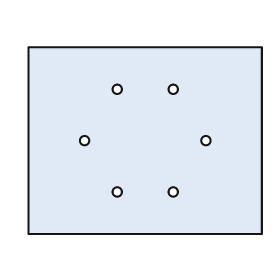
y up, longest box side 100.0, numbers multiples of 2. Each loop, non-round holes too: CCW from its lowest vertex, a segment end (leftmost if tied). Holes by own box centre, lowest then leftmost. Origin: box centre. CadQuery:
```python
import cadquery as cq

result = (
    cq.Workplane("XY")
    .moveTo(-50.0, -40.0)
    .lineTo(50.0, -40.0)
    .lineTo(50.0, 40.0)
    .lineTo(-50.0, 40.0)
    .close()
    .moveTo(-12.0, -22.0)
    .circle(2.0)
    .moveTo(12.0, -22.0)
    .circle(2.0)
    .moveTo(-26.0, 0.0)
    .circle(2.0)
    .moveTo(26.0, 0.0)
    .circle(2.0)
    .moveTo(-12.0, 22.0)
    .circle(2.0)
    .moveTo(12.0, 22.0)
    .circle(2.0)
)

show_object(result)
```